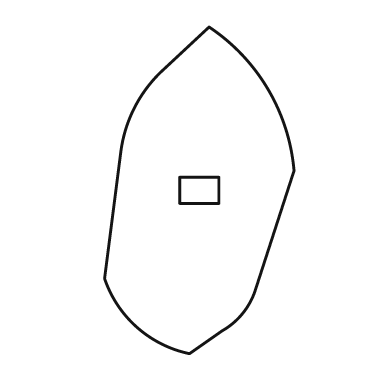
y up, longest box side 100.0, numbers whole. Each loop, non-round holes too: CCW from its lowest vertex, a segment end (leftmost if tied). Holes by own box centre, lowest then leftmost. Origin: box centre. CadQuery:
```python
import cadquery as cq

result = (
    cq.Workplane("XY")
    .moveTo(-3.0, -50.0)
    .lineTo(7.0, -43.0)
    .threePointArc((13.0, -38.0), (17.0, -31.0))
    .lineTo(29.0, 6.0)
    .threePointArc((21.0, 31.0), (3.0, 50.0))
    .lineTo(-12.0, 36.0)
    .threePointArc((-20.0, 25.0), (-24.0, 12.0))
    .lineTo(-29.0, -27.0)
    .threePointArc((-19.0, -42.0), (-3.0, -50.0))
    .close()
    .moveTo(-6.0, -4.0)
    .lineTo(6.0, -4.0)
    .lineTo(6.0, 4.0)
    .lineTo(-6.0, 4.0)
    .close()
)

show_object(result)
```